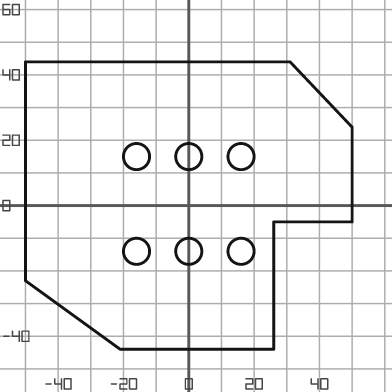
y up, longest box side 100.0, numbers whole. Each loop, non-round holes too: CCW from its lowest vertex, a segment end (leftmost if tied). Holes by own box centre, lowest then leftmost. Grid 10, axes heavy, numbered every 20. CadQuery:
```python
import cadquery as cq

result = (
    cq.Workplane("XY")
    .moveTo(-21.0, -44.0)
    .lineTo(26.0, -44.0)
    .lineTo(26.0, -5.0)
    .lineTo(50.0, -5.0)
    .lineTo(50.0, 24.0)
    .lineTo(31.0, 44.0)
    .lineTo(-50.0, 44.0)
    .lineTo(-50.0, -23.0)
    .close()
    .moveTo(-16.0, -14.0)
    .circle(4.0)
    .moveTo(0.0, -14.0)
    .circle(4.0)
    .moveTo(16.0, -14.0)
    .circle(4.0)
    .moveTo(-16.0, 15.0)
    .circle(4.0)
    .moveTo(0.0, 15.0)
    .circle(4.0)
    .moveTo(16.0, 15.0)
    .circle(4.0)
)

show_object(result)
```